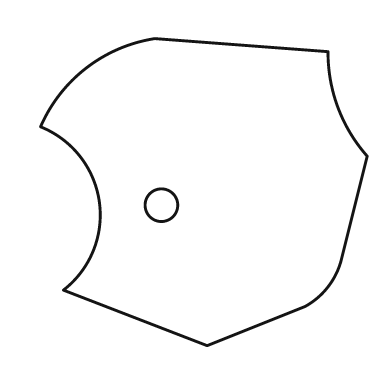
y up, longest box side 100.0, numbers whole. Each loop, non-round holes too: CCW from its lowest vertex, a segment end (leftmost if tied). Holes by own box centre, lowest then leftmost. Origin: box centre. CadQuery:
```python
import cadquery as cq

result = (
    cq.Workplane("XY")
    .moveTo(1.0, -47.0)
    .lineTo(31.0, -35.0)
    .threePointArc((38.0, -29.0), (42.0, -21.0))
    .lineTo(50.0, 11.0)
    .threePointArc((41.0, 26.0), (38.0, 43.0))
    .lineTo(-15.0, 47.0)
    .threePointArc((-36.0, 38.0), (-50.0, 20.0))
    .threePointArc((-32.0, -3.0), (-43.0, -30.0))
    .close()
    .moveTo(-13.0, -4.0)
    .circle(5.0)
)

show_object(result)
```